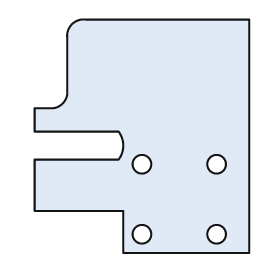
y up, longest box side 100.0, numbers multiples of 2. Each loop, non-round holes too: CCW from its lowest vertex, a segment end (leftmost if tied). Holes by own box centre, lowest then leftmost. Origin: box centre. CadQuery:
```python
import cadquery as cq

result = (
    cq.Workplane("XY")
    .moveTo(-8.0, -50.0)
    .lineTo(46.0, -50.0)
    .lineTo(46.0, 50.0)
    .lineTo(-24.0, 50.0)
    .threePointArc((-30.0, 48.0), (-32.0, 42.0))
    .lineTo(-32.0, 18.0)
    .threePointArc((-34.0, 14.0), (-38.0, 12.0))
    .lineTo(-46.0, 12.0)
    .lineTo(-46.0, 2.0)
    .lineTo(-10.0, 2.0)
    .threePointArc((-8.0, -4.0), (-10.0, -10.0))
    .lineTo(-46.0, -10.0)
    .lineTo(-46.0, -32.0)
    .lineTo(-8.0, -32.0)
    .close()
    .moveTo(0.0, -42.0)
    .circle(4.0)
    .moveTo(32.0, -42.0)
    .circle(4.0)
    .moveTo(0.0, -12.0)
    .circle(4.0)
    .moveTo(32.0, -12.0)
    .circle(4.0)
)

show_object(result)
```